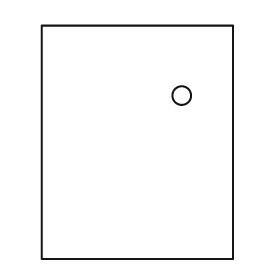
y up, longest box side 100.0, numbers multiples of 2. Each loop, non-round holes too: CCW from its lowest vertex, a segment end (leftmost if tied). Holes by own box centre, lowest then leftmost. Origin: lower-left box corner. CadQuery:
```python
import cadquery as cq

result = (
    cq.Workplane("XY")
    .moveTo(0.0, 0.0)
    .lineTo(82.0, 0.0)
    .lineTo(82.0, 100.0)
    .lineTo(0.0, 100.0)
    .close()
    .moveTo(60.0, 70.0)
    .circle(4.0)
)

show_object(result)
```